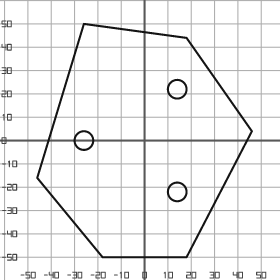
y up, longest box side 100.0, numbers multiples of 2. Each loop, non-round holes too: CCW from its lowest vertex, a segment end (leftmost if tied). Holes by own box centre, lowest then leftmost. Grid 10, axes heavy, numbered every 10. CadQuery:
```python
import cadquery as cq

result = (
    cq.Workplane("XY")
    .moveTo(-18.0, -50.0)
    .lineTo(18.0, -50.0)
    .lineTo(46.0, 4.0)
    .lineTo(18.0, 44.0)
    .lineTo(-26.0, 50.0)
    .lineTo(-46.0, -16.0)
    .close()
    .moveTo(14.0, -22.0)
    .circle(4.0)
    .moveTo(-26.0, 0.0)
    .circle(4.0)
    .moveTo(14.0, 22.0)
    .circle(4.0)
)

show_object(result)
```